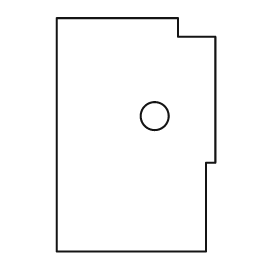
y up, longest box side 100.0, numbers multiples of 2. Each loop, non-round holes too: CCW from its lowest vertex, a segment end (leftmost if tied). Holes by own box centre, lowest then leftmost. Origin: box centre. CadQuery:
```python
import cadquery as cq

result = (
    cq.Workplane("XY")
    .moveTo(-34.0, -50.0)
    .lineTo(30.0, -50.0)
    .lineTo(30.0, -12.0)
    .lineTo(34.0, -12.0)
    .lineTo(34.0, 42.0)
    .lineTo(18.0, 42.0)
    .lineTo(18.0, 50.0)
    .lineTo(-34.0, 50.0)
    .close()
    .moveTo(8.0, 8.0)
    .circle(6.0)
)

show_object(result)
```